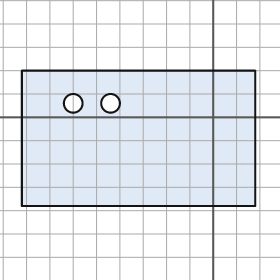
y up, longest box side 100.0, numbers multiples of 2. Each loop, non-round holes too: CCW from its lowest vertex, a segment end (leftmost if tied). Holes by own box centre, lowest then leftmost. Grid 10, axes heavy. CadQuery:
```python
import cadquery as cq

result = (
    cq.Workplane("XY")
    .moveTo(-82.0, -38.0)
    .lineTo(18.0, -38.0)
    .lineTo(18.0, 20.0)
    .lineTo(-82.0, 20.0)
    .close()
    .moveTo(-60.0, 6.0)
    .circle(4.0)
    .moveTo(-44.0, 6.0)
    .circle(4.0)
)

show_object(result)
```